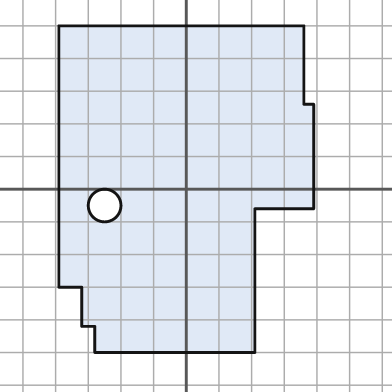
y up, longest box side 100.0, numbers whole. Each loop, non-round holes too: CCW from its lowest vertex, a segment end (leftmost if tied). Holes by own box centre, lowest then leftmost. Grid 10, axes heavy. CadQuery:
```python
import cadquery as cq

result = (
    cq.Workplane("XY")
    .moveTo(-28.0, -50.0)
    .lineTo(21.0, -50.0)
    .lineTo(21.0, -6.0)
    .lineTo(39.0, -6.0)
    .lineTo(39.0, 26.0)
    .lineTo(36.0, 26.0)
    .lineTo(36.0, 50.0)
    .lineTo(-39.0, 50.0)
    .lineTo(-39.0, -30.0)
    .lineTo(-32.0, -30.0)
    .lineTo(-32.0, -42.0)
    .lineTo(-28.0, -42.0)
    .close()
    .moveTo(-25.0, -5.0)
    .circle(5.0)
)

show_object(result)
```